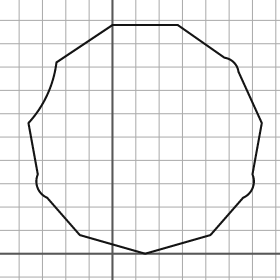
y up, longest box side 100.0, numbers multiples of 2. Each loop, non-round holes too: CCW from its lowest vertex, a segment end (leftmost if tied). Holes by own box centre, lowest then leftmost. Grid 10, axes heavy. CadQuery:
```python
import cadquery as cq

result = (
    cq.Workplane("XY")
    .moveTo(14.0, 0.0)
    .lineTo(42.0, 8.0)
    .lineTo(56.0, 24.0)
    .threePointArc((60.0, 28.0), (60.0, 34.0))
    .lineTo(64.0, 56.0)
    .lineTo(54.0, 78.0)
    .threePointArc((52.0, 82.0), (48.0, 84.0))
    .lineTo(28.0, 98.0)
    .lineTo(0.0, 98.0)
    .lineTo(-24.0, 82.0)
    .threePointArc((-28.0, 68.0), (-36.0, 56.0))
    .lineTo(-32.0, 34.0)
    .threePointArc((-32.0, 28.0), (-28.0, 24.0))
    .lineTo(-14.0, 8.0)
    .close()
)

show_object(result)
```